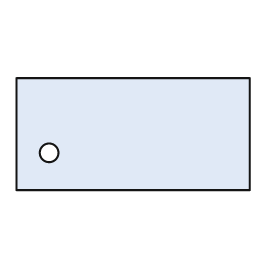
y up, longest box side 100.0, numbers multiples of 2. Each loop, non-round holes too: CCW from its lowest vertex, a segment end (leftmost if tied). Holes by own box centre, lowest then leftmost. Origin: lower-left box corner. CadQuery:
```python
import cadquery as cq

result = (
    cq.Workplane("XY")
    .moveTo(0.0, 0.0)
    .lineTo(100.0, 0.0)
    .lineTo(100.0, 48.0)
    .lineTo(0.0, 48.0)
    .close()
    .moveTo(14.0, 16.0)
    .circle(4.0)
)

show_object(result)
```